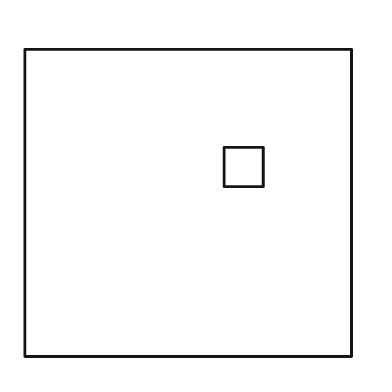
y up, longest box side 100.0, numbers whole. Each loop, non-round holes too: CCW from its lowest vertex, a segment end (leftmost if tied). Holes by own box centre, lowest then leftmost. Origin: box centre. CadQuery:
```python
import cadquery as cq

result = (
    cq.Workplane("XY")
    .moveTo(-50.0, -47.0)
    .lineTo(50.0, -47.0)
    .lineTo(50.0, 47.0)
    .lineTo(-50.0, 47.0)
    .close()
    .moveTo(11.0, 5.0)
    .lineTo(23.0, 5.0)
    .lineTo(23.0, 17.0)
    .lineTo(11.0, 17.0)
    .close()
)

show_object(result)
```